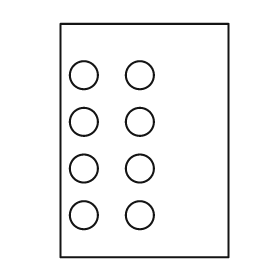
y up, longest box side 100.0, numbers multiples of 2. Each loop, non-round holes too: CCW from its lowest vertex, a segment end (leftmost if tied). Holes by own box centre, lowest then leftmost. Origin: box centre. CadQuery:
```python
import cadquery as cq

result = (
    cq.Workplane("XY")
    .moveTo(-36.0, -50.0)
    .lineTo(36.0, -50.0)
    .lineTo(36.0, 50.0)
    .lineTo(-36.0, 50.0)
    .close()
    .moveTo(-26.0, -32.0)
    .circle(6.0)
    .moveTo(-2.0, -32.0)
    .circle(6.0)
    .moveTo(-26.0, -12.0)
    .circle(6.0)
    .moveTo(-2.0, -12.0)
    .circle(6.0)
    .moveTo(-26.0, 8.0)
    .circle(6.0)
    .moveTo(-2.0, 8.0)
    .circle(6.0)
    .moveTo(-26.0, 28.0)
    .circle(6.0)
    .moveTo(-2.0, 28.0)
    .circle(6.0)
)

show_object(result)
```